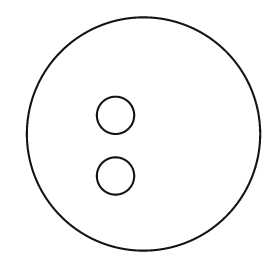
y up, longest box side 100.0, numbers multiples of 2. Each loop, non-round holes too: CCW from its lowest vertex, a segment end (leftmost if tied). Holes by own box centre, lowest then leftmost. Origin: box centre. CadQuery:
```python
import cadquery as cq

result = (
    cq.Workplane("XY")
    .moveTo(0.0, 0.0)
    .circle(50.0)
    .moveTo(-12.0, -18.0)
    .circle(8.0)
    .moveTo(-12.0, 8.0)
    .circle(8.0)
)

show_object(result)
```